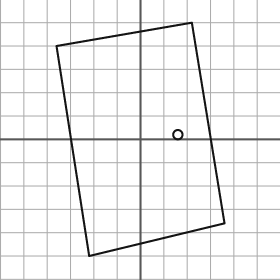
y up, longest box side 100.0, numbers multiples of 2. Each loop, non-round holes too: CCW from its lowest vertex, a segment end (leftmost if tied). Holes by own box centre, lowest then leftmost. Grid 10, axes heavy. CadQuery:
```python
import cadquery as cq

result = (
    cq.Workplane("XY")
    .moveTo(-22.0, -50.0)
    .lineTo(36.0, -36.0)
    .lineTo(22.0, 50.0)
    .lineTo(-36.0, 40.0)
    .close()
    .moveTo(16.0, 2.0)
    .circle(2.0)
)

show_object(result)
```